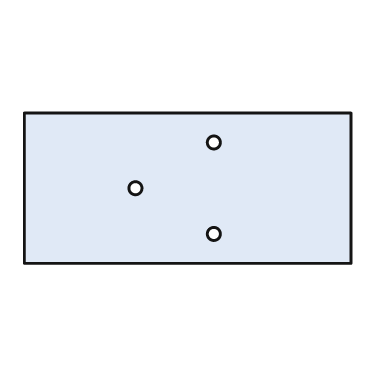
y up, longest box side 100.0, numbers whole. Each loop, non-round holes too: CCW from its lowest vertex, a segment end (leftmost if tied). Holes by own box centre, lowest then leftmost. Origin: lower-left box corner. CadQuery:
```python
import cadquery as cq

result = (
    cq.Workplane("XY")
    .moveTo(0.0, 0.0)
    .lineTo(100.0, 0.0)
    .lineTo(100.0, 46.0)
    .lineTo(0.0, 46.0)
    .close()
    .moveTo(58.0, 9.0)
    .circle(2.0)
    .moveTo(34.0, 23.0)
    .circle(2.0)
    .moveTo(58.0, 37.0)
    .circle(2.0)
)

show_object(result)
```